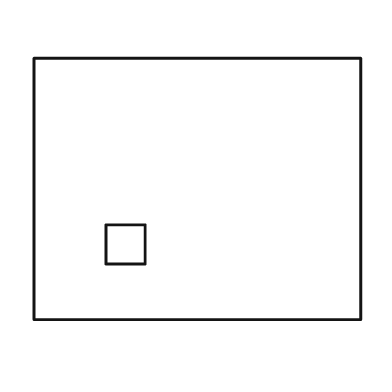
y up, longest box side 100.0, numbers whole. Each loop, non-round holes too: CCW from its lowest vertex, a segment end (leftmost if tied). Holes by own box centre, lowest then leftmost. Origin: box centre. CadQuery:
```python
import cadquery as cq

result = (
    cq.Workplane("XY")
    .moveTo(-50.0, -40.0)
    .lineTo(50.0, -40.0)
    .lineTo(50.0, 40.0)
    .lineTo(-50.0, 40.0)
    .close()
    .moveTo(-28.0, -23.0)
    .lineTo(-16.0, -23.0)
    .lineTo(-16.0, -11.0)
    .lineTo(-28.0, -11.0)
    .close()
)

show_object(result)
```